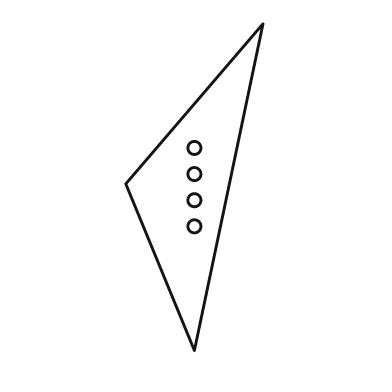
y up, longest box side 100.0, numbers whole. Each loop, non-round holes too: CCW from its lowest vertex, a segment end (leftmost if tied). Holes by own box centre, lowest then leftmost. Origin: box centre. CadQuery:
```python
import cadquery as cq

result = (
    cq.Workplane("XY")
    .moveTo(0.0, -50.0)
    .lineTo(21.0, 50.0)
    .lineTo(-21.0, 1.0)
    .close()
    .moveTo(0.0, -12.0)
    .circle(2.0)
    .moveTo(0.0, -4.0)
    .circle(2.0)
    .moveTo(0.0, 4.0)
    .circle(2.0)
    .moveTo(0.0, 12.0)
    .circle(2.0)
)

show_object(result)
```